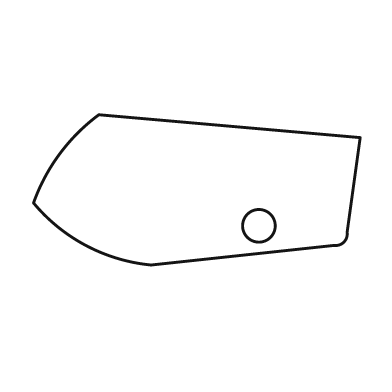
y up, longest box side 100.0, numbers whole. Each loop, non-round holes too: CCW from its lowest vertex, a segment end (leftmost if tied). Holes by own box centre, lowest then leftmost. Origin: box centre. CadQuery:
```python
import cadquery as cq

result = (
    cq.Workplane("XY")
    .moveTo(-14.0, -23.0)
    .lineTo(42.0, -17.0)
    .threePointArc((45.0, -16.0), (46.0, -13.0))
    .lineTo(50.0, 16.0)
    .lineTo(-30.0, 23.0)
    .threePointArc((-42.0, 11.0), (-50.0, -4.0))
    .threePointArc((-34.0, -17.0), (-14.0, -23.0))
    .close()
    .moveTo(19.0, -11.0)
    .circle(5.0)
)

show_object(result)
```